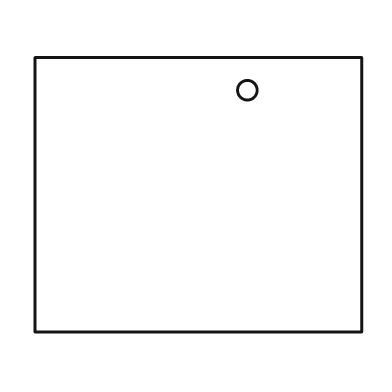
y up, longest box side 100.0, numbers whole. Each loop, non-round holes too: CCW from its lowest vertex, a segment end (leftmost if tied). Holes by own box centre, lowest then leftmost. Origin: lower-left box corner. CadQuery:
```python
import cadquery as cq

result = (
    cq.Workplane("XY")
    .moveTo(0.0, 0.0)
    .lineTo(100.0, 0.0)
    .lineTo(100.0, 84.0)
    .lineTo(0.0, 84.0)
    .close()
    .moveTo(65.0, 74.0)
    .circle(3.0)
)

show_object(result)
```